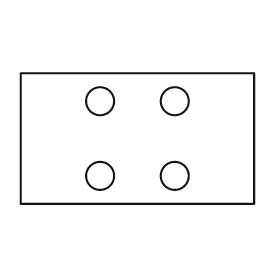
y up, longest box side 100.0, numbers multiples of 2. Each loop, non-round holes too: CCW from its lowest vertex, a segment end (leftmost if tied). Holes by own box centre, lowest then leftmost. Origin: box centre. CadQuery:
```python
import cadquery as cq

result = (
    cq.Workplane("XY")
    .moveTo(-50.0, -28.0)
    .lineTo(50.0, -28.0)
    .lineTo(50.0, 28.0)
    .lineTo(-50.0, 28.0)
    .close()
    .moveTo(-16.0, -16.0)
    .circle(6.0)
    .moveTo(16.0, -16.0)
    .circle(6.0)
    .moveTo(-16.0, 16.0)
    .circle(6.0)
    .moveTo(16.0, 16.0)
    .circle(6.0)
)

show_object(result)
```